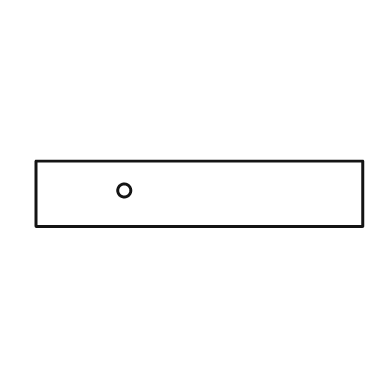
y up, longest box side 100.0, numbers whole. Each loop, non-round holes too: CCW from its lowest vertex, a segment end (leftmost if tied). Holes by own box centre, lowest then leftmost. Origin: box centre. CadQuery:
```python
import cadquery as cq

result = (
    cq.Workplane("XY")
    .moveTo(-50.0, -10.0)
    .lineTo(50.0, -10.0)
    .lineTo(50.0, 10.0)
    .lineTo(-50.0, 10.0)
    .close()
    .moveTo(-23.0, 1.0)
    .circle(2.0)
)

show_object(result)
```